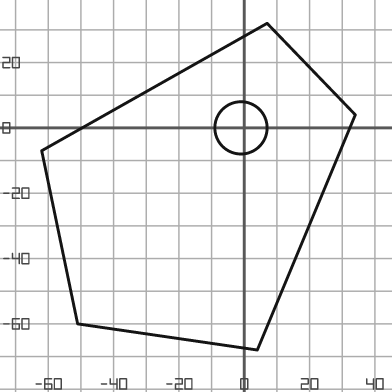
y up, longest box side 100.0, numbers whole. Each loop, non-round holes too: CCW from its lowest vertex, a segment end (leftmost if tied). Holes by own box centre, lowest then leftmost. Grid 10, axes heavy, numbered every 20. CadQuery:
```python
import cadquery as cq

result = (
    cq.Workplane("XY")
    .moveTo(4.0, -68.0)
    .lineTo(34.0, 4.0)
    .lineTo(7.0, 32.0)
    .lineTo(-62.0, -7.0)
    .lineTo(-51.0, -60.0)
    .close()
    .moveTo(-1.0, 0.0)
    .circle(8.0)
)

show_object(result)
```